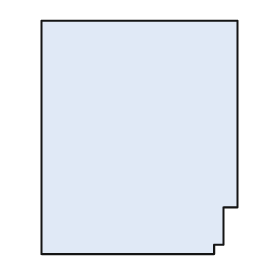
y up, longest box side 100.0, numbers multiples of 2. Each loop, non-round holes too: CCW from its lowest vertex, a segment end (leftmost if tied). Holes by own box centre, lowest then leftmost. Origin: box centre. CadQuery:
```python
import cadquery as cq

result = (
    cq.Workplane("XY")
    .moveTo(-42.0, -50.0)
    .lineTo(32.0, -50.0)
    .lineTo(32.0, -46.0)
    .lineTo(36.0, -46.0)
    .lineTo(36.0, -30.0)
    .lineTo(42.0, -30.0)
    .lineTo(42.0, 50.0)
    .lineTo(-42.0, 50.0)
    .close()
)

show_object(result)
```